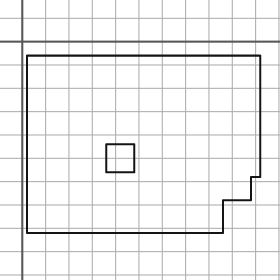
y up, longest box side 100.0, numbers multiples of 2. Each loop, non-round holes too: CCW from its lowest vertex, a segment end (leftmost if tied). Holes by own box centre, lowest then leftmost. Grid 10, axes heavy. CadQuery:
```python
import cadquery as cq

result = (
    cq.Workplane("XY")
    .moveTo(2.0, -82.0)
    .lineTo(86.0, -82.0)
    .lineTo(86.0, -68.0)
    .lineTo(98.0, -68.0)
    .lineTo(98.0, -58.0)
    .lineTo(102.0, -58.0)
    .lineTo(102.0, -6.0)
    .lineTo(2.0, -6.0)
    .close()
    .moveTo(36.0, -56.0)
    .lineTo(48.0, -56.0)
    .lineTo(48.0, -44.0)
    .lineTo(36.0, -44.0)
    .close()
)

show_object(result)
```